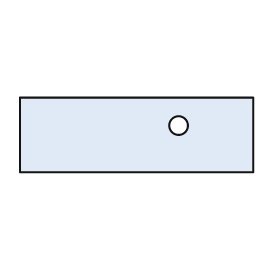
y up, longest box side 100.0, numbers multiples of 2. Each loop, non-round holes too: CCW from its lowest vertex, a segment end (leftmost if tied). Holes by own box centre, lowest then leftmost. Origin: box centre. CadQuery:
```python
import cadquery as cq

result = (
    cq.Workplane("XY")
    .moveTo(-50.0, -16.0)
    .lineTo(50.0, -16.0)
    .lineTo(50.0, 16.0)
    .lineTo(-50.0, 16.0)
    .close()
    .moveTo(18.0, 4.0)
    .circle(4.0)
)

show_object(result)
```